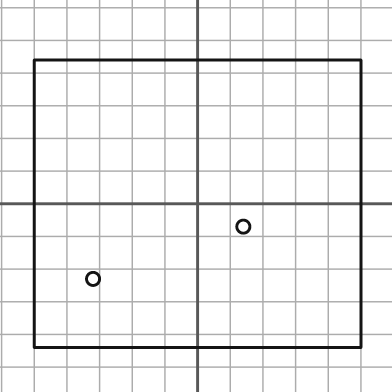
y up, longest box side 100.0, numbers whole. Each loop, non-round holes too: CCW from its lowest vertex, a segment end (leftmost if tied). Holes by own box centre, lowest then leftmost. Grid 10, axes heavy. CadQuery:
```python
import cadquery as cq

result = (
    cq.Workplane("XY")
    .moveTo(-50.0, -44.0)
    .lineTo(50.0, -44.0)
    .lineTo(50.0, 44.0)
    .lineTo(-50.0, 44.0)
    .close()
    .moveTo(-32.0, -23.0)
    .circle(2.0)
    .moveTo(14.0, -7.0)
    .circle(2.0)
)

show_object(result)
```